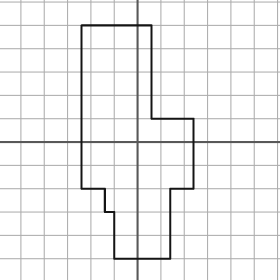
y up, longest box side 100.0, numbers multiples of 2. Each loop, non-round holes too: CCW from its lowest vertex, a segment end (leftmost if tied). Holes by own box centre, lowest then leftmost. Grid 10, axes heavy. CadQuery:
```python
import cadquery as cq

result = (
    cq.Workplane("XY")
    .moveTo(-10.0, -50.0)
    .lineTo(14.0, -50.0)
    .lineTo(14.0, -20.0)
    .lineTo(24.0, -20.0)
    .lineTo(24.0, 10.0)
    .lineTo(6.0, 10.0)
    .lineTo(6.0, 50.0)
    .lineTo(-24.0, 50.0)
    .lineTo(-24.0, -20.0)
    .lineTo(-14.0, -20.0)
    .lineTo(-14.0, -30.0)
    .lineTo(-10.0, -30.0)
    .close()
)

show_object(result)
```